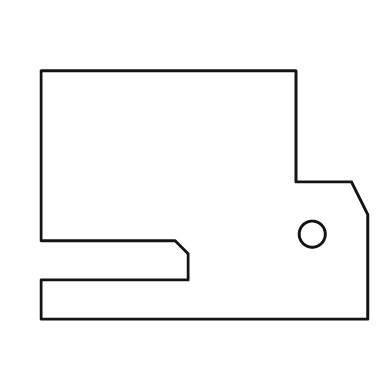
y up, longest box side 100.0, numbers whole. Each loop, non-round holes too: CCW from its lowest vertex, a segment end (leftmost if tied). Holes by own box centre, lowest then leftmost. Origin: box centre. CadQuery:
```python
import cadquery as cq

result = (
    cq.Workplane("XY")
    .moveTo(-50.0, -38.0)
    .lineTo(50.0, -38.0)
    .lineTo(50.0, -6.0)
    .lineTo(45.0, 4.0)
    .lineTo(28.0, 4.0)
    .lineTo(28.0, 38.0)
    .lineTo(-50.0, 38.0)
    .lineTo(-50.0, -14.0)
    .lineTo(-9.0, -14.0)
    .lineTo(-5.0, -18.0)
    .lineTo(-5.0, -26.0)
    .lineTo(-50.0, -26.0)
    .close()
    .moveTo(33.0, -12.0)
    .circle(4.0)
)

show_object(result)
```